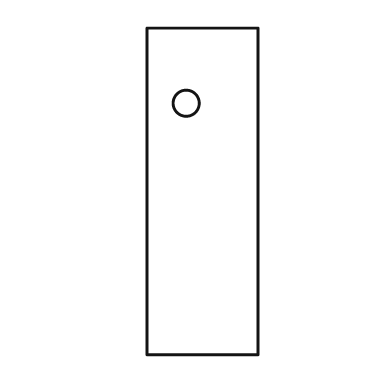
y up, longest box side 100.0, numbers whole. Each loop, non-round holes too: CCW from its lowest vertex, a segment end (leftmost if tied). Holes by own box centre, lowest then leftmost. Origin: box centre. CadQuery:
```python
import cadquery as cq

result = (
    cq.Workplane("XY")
    .moveTo(-17.0, -50.0)
    .lineTo(17.0, -50.0)
    .lineTo(17.0, 50.0)
    .lineTo(-17.0, 50.0)
    .close()
    .moveTo(-5.0, 27.0)
    .circle(4.0)
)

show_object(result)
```